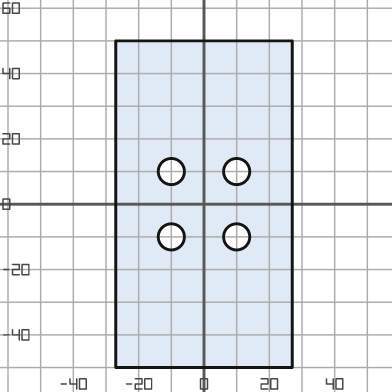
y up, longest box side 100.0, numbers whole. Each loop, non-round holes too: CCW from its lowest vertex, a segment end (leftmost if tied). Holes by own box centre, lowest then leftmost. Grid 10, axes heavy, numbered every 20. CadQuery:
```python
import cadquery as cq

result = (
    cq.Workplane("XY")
    .moveTo(-27.0, -50.0)
    .lineTo(27.0, -50.0)
    .lineTo(27.0, 50.0)
    .lineTo(-27.0, 50.0)
    .close()
    .moveTo(-10.0, -10.0)
    .circle(4.0)
    .moveTo(10.0, -10.0)
    .circle(4.0)
    .moveTo(-10.0, 10.0)
    .circle(4.0)
    .moveTo(10.0, 10.0)
    .circle(4.0)
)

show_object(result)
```